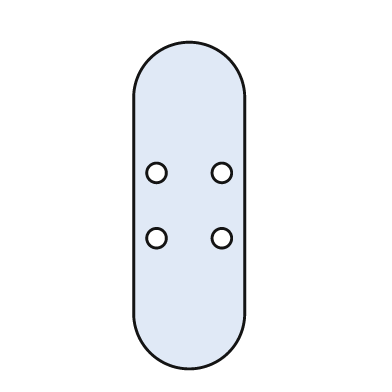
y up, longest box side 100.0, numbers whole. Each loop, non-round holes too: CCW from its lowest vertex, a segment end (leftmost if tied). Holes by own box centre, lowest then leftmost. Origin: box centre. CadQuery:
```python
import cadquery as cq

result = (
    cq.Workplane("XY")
    .moveTo(-17.0, -33.0)
    .threePointArc((0.0, -50.0), (17.0, -33.0))
    .lineTo(17.0, 33.0)
    .threePointArc((0.0, 50.0), (-17.0, 33.0))
    .close()
    .moveTo(-10.0, -10.0)
    .circle(3.0)
    .moveTo(10.0, -10.0)
    .circle(3.0)
    .moveTo(-10.0, 10.0)
    .circle(3.0)
    .moveTo(10.0, 10.0)
    .circle(3.0)
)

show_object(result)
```